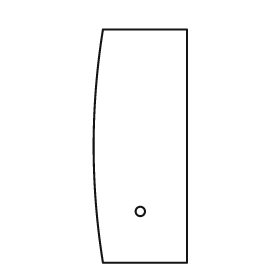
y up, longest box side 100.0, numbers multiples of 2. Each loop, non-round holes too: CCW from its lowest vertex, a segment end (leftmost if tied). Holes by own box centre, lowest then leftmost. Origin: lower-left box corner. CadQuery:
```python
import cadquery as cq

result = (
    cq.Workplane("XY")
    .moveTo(4.0, 0.0)
    .lineTo(40.0, 0.0)
    .lineTo(40.0, 100.0)
    .lineTo(4.0, 100.0)
    .threePointArc((0.0, 50.0), (4.0, 0.0))
    .close()
    .moveTo(20.0, 22.0)
    .circle(2.0)
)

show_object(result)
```